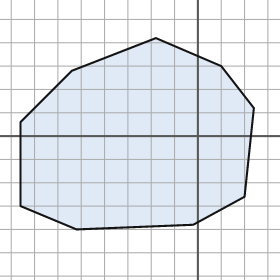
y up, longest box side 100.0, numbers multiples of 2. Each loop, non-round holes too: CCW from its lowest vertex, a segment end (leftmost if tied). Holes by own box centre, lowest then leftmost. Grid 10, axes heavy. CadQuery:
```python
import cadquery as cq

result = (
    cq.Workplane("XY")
    .moveTo(-52.0, -40.0)
    .lineTo(-2.0, -38.0)
    .lineTo(20.0, -26.0)
    .lineTo(24.0, 12.0)
    .lineTo(10.0, 30.0)
    .lineTo(-18.0, 42.0)
    .lineTo(-54.0, 28.0)
    .lineTo(-76.0, 6.0)
    .lineTo(-76.0, -30.0)
    .close()
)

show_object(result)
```